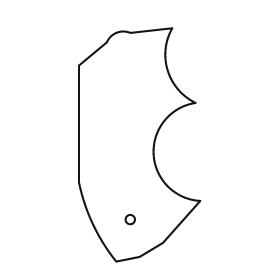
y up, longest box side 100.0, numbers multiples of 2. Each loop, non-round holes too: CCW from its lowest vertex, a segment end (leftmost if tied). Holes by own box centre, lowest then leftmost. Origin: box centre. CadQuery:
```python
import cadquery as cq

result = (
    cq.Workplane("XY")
    .moveTo(-10.0, -50.0)
    .lineTo(0.0, -48.0)
    .lineTo(10.0, -42.0)
    .lineTo(26.0, -24.0)
    .threePointArc((6.0, -4.0), (24.0, 18.0))
    .threePointArc((12.0, 32.0), (14.0, 50.0))
    .lineTo(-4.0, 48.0)
    .threePointArc((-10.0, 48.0), (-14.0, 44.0))
    .lineTo(-26.0, 34.0)
    .lineTo(-26.0, -16.0)
    .threePointArc((-20.0, -34.0), (-10.0, -50.0))
    .close()
    .moveTo(-4.0, -32.0)
    .circle(2.0)
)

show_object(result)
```